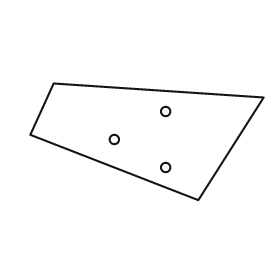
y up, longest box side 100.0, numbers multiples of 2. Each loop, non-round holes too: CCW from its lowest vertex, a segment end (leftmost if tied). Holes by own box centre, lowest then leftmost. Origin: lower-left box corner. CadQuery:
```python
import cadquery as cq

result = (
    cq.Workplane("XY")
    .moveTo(72.0, 0.0)
    .lineTo(100.0, 44.0)
    .lineTo(10.0, 50.0)
    .lineTo(0.0, 28.0)
    .close()
    .moveTo(58.0, 14.0)
    .circle(2.0)
    .moveTo(36.0, 26.0)
    .circle(2.0)
    .moveTo(58.0, 38.0)
    .circle(2.0)
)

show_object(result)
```